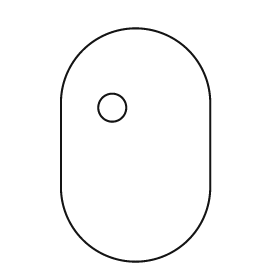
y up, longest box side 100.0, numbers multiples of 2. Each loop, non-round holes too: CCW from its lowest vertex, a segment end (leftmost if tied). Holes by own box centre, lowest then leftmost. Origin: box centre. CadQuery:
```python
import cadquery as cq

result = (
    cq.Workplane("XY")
    .moveTo(-32.0, -18.0)
    .threePointArc((0.0, -50.0), (32.0, -18.0))
    .lineTo(32.0, 18.0)
    .threePointArc((0.0, 50.0), (-32.0, 18.0))
    .close()
    .moveTo(-10.0, 16.0)
    .circle(6.0)
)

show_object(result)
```